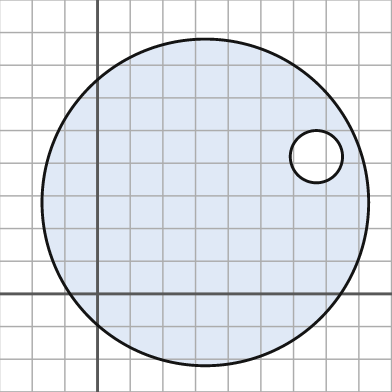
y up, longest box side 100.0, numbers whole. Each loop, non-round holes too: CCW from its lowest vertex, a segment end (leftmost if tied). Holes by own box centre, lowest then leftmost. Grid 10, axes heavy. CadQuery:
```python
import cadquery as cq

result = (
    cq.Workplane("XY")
    .moveTo(33.0, 28.0)
    .circle(50.0)
    .moveTo(67.0, 42.0)
    .circle(8.0)
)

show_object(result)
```